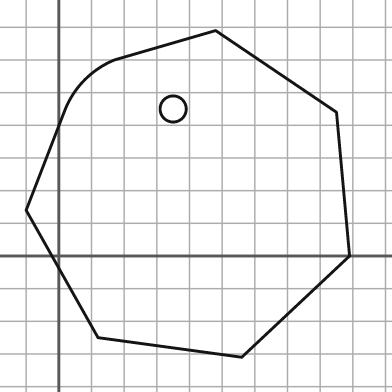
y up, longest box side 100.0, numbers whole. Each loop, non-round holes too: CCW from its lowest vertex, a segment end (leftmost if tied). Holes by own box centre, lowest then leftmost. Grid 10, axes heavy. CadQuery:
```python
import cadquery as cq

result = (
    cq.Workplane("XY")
    .moveTo(56.0, -31.0)
    .lineTo(89.0, 0.0)
    .lineTo(85.0, 44.0)
    .lineTo(48.0, 69.0)
    .lineTo(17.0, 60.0)
    .threePointArc((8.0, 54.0), (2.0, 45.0))
    .lineTo(-10.0, 14.0)
    .lineTo(12.0, -25.0)
    .close()
    .moveTo(35.0, 45.0)
    .circle(4.0)
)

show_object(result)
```